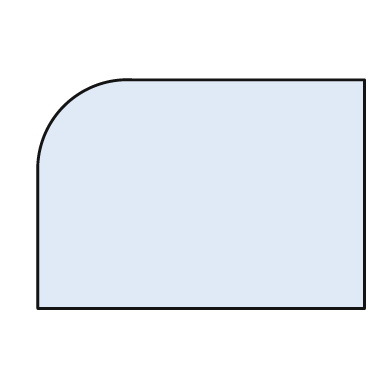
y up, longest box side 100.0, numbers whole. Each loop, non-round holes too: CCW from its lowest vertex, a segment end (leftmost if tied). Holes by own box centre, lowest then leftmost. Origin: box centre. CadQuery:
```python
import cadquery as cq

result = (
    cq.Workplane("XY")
    .moveTo(-50.0, -35.0)
    .lineTo(50.0, -35.0)
    .lineTo(50.0, 35.0)
    .lineTo(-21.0, 35.0)
    .threePointArc((-42.0, 27.0), (-50.0, 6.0))
    .close()
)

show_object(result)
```